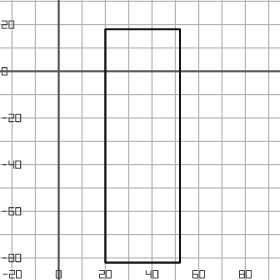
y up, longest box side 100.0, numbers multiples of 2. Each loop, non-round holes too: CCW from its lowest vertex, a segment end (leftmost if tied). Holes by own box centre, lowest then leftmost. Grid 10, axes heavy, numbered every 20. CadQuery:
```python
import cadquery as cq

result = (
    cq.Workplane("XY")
    .moveTo(20.0, -82.0)
    .lineTo(52.0, -82.0)
    .lineTo(52.0, 18.0)
    .lineTo(20.0, 18.0)
    .close()
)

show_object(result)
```